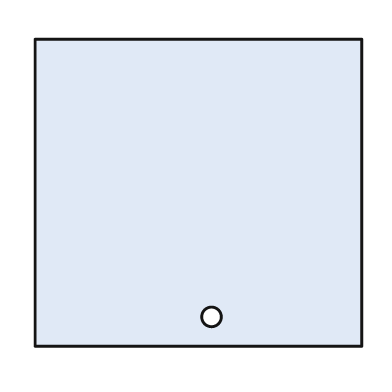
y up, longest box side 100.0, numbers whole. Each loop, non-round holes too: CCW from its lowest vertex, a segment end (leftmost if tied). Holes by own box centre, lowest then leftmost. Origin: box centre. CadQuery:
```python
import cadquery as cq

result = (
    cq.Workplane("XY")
    .moveTo(-50.0, -47.0)
    .lineTo(50.0, -47.0)
    .lineTo(50.0, 47.0)
    .lineTo(-50.0, 47.0)
    .close()
    .moveTo(4.0, -38.0)
    .circle(3.0)
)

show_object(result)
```